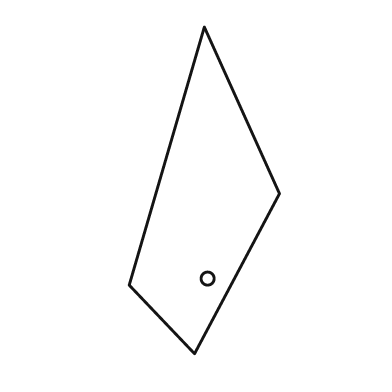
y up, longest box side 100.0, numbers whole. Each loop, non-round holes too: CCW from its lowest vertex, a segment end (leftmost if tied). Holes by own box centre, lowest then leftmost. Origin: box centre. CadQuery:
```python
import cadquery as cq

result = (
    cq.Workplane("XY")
    .moveTo(-3.0, -50.0)
    .lineTo(23.0, -1.0)
    .lineTo(0.0, 50.0)
    .lineTo(-23.0, -29.0)
    .close()
    .moveTo(1.0, -27.0)
    .circle(2.0)
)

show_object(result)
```